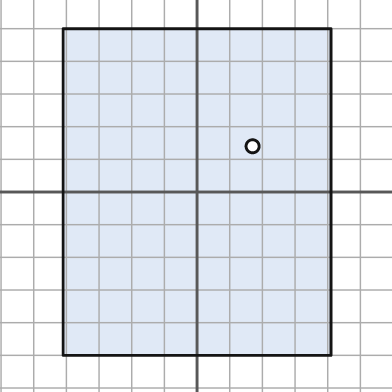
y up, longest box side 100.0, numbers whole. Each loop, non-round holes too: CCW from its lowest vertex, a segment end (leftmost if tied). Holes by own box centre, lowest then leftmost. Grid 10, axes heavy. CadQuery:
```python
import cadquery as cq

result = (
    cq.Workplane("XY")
    .moveTo(-41.0, -50.0)
    .lineTo(41.0, -50.0)
    .lineTo(41.0, 50.0)
    .lineTo(-41.0, 50.0)
    .close()
    .moveTo(17.0, 14.0)
    .circle(2.0)
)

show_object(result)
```